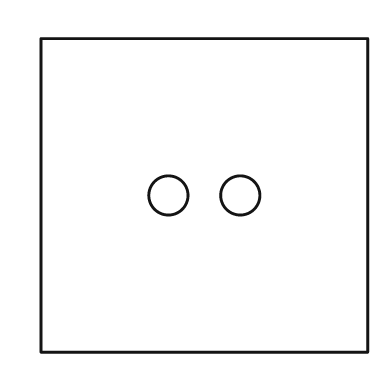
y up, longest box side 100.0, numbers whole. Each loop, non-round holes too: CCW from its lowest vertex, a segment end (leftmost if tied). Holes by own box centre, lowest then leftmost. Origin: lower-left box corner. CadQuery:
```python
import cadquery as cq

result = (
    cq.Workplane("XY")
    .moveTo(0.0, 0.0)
    .lineTo(100.0, 0.0)
    .lineTo(100.0, 96.0)
    .lineTo(0.0, 96.0)
    .close()
    .moveTo(39.0, 48.0)
    .circle(6.0)
    .moveTo(61.0, 48.0)
    .circle(6.0)
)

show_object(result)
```